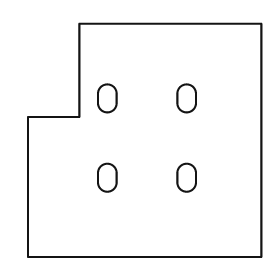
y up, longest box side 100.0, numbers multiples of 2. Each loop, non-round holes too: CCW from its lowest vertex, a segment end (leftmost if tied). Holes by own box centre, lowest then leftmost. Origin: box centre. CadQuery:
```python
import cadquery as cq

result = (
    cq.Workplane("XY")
    .moveTo(-50.0, -50.0)
    .lineTo(50.0, -50.0)
    .lineTo(50.0, 50.0)
    .lineTo(-28.0, 50.0)
    .lineTo(-28.0, 10.0)
    .lineTo(-50.0, 10.0)
    .close()
    .moveTo(-20.0, -18.0)
    .threePointArc((-16.0, -22.0), (-12.0, -18.0))
    .lineTo(-12.0, -14.0)
    .threePointArc((-16.0, -10.0), (-20.0, -14.0))
    .close()
    .moveTo(14.0, -18.0)
    .threePointArc((18.0, -22.0), (22.0, -18.0))
    .lineTo(22.0, -14.0)
    .threePointArc((18.0, -10.0), (14.0, -14.0))
    .close()
    .moveTo(-20.0, 16.0)
    .threePointArc((-16.0, 12.0), (-12.0, 16.0))
    .lineTo(-12.0, 20.0)
    .threePointArc((-16.0, 24.0), (-20.0, 20.0))
    .close()
    .moveTo(14.0, 16.0)
    .threePointArc((18.0, 12.0), (22.0, 16.0))
    .lineTo(22.0, 20.0)
    .threePointArc((18.0, 24.0), (14.0, 20.0))
    .close()
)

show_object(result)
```